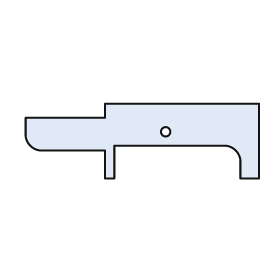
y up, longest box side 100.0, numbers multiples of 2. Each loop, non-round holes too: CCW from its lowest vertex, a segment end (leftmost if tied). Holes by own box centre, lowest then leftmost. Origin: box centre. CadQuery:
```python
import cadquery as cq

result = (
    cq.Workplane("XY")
    .moveTo(-16.0, -16.0)
    .lineTo(-12.0, -16.0)
    .lineTo(-12.0, -2.0)
    .lineTo(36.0, -2.0)
    .threePointArc((40.0, -4.0), (42.0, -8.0))
    .lineTo(42.0, -16.0)
    .lineTo(50.0, -16.0)
    .lineTo(50.0, 16.0)
    .lineTo(-16.0, 16.0)
    .lineTo(-16.0, 10.0)
    .lineTo(-50.0, 10.0)
    .lineTo(-50.0, 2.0)
    .threePointArc((-48.0, -2.0), (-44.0, -4.0))
    .lineTo(-16.0, -4.0)
    .close()
    .moveTo(10.0, 4.0)
    .circle(2.0)
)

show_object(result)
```